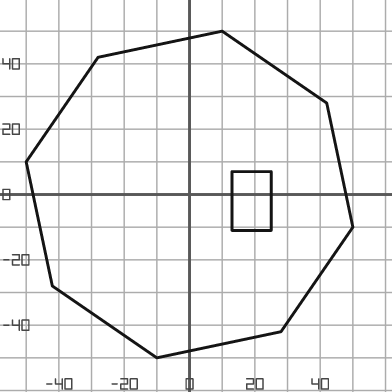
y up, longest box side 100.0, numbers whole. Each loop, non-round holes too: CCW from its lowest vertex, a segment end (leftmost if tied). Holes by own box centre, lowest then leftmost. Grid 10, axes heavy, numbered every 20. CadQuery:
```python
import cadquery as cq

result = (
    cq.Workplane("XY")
    .moveTo(-10.0, -50.0)
    .lineTo(28.0, -42.0)
    .lineTo(50.0, -10.0)
    .lineTo(42.0, 28.0)
    .lineTo(10.0, 50.0)
    .lineTo(-28.0, 42.0)
    .lineTo(-50.0, 10.0)
    .lineTo(-42.0, -28.0)
    .close()
    .moveTo(13.0, -11.0)
    .lineTo(25.0, -11.0)
    .lineTo(25.0, 7.0)
    .lineTo(13.0, 7.0)
    .close()
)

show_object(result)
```